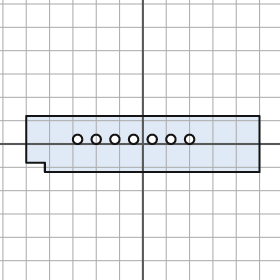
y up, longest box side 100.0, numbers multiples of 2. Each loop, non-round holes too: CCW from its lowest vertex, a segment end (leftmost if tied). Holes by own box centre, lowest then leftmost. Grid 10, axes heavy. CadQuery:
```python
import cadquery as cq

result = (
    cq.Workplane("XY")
    .moveTo(-42.0, -12.0)
    .lineTo(50.0, -12.0)
    .lineTo(50.0, 12.0)
    .lineTo(-50.0, 12.0)
    .lineTo(-50.0, -8.0)
    .lineTo(-42.0, -8.0)
    .close()
    .moveTo(-28.0, 2.0)
    .circle(2.0)
    .moveTo(-20.0, 2.0)
    .circle(2.0)
    .moveTo(-12.0, 2.0)
    .circle(2.0)
    .moveTo(-4.0, 2.0)
    .circle(2.0)
    .moveTo(4.0, 2.0)
    .circle(2.0)
    .moveTo(12.0, 2.0)
    .circle(2.0)
    .moveTo(20.0, 2.0)
    .circle(2.0)
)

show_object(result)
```